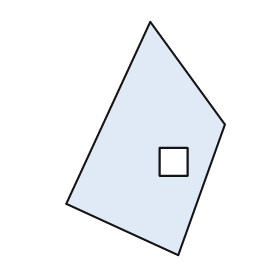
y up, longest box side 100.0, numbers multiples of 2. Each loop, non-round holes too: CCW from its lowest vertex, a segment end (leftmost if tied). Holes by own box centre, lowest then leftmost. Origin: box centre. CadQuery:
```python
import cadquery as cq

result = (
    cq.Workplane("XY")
    .moveTo(14.0, -50.0)
    .lineTo(34.0, 6.0)
    .lineTo(2.0, 50.0)
    .lineTo(-34.0, -28.0)
    .close()
    .moveTo(6.0, -16.0)
    .lineTo(18.0, -16.0)
    .lineTo(18.0, -4.0)
    .lineTo(6.0, -4.0)
    .close()
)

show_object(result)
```